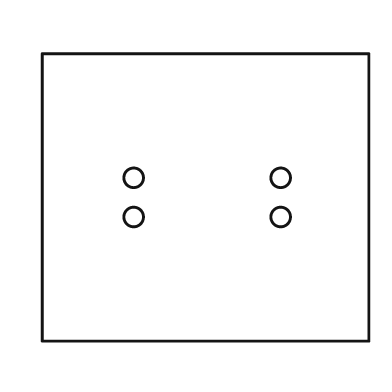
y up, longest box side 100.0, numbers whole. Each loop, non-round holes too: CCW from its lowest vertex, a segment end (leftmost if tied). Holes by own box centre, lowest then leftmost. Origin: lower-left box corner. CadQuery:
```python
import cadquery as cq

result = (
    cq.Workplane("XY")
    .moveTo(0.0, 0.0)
    .lineTo(100.0, 0.0)
    .lineTo(100.0, 88.0)
    .lineTo(0.0, 88.0)
    .close()
    .moveTo(28.0, 38.0)
    .circle(3.0)
    .moveTo(73.0, 38.0)
    .circle(3.0)
    .moveTo(28.0, 50.0)
    .circle(3.0)
    .moveTo(73.0, 50.0)
    .circle(3.0)
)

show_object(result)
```